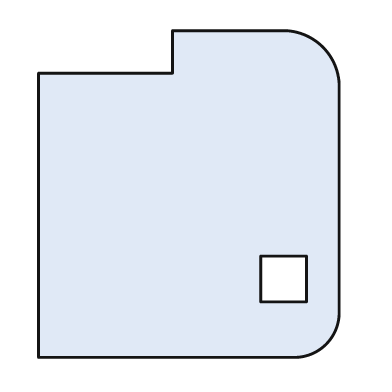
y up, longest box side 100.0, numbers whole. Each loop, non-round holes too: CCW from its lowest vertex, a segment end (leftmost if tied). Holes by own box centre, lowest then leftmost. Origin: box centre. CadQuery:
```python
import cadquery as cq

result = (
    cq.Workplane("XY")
    .moveTo(-46.0, -50.0)
    .lineTo(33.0, -50.0)
    .threePointArc((42.0, -46.0), (46.0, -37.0))
    .lineTo(46.0, 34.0)
    .threePointArc((41.0, 45.0), (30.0, 50.0))
    .lineTo(-5.0, 50.0)
    .lineTo(-5.0, 37.0)
    .lineTo(-46.0, 37.0)
    .close()
    .moveTo(22.0, -33.0)
    .lineTo(36.0, -33.0)
    .lineTo(36.0, -19.0)
    .lineTo(22.0, -19.0)
    .close()
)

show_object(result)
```